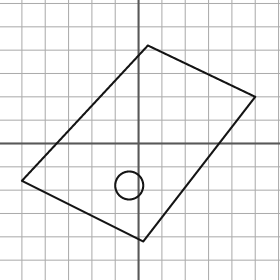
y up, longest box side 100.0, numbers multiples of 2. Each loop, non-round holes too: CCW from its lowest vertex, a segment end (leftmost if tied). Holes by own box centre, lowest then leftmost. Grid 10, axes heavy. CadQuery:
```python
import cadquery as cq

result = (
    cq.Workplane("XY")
    .moveTo(2.0, -42.0)
    .lineTo(50.0, 20.0)
    .lineTo(4.0, 42.0)
    .lineTo(-50.0, -16.0)
    .close()
    .moveTo(-4.0, -18.0)
    .circle(6.0)
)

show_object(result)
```